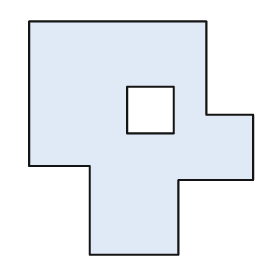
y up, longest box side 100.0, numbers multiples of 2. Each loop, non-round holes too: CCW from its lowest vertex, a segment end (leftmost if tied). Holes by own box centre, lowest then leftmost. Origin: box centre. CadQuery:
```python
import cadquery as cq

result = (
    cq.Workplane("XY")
    .moveTo(-22.0, -50.0)
    .lineTo(16.0, -50.0)
    .lineTo(16.0, -18.0)
    .lineTo(48.0, -18.0)
    .lineTo(48.0, 10.0)
    .lineTo(28.0, 10.0)
    .lineTo(28.0, 50.0)
    .lineTo(-48.0, 50.0)
    .lineTo(-48.0, -12.0)
    .lineTo(-22.0, -12.0)
    .close()
    .moveTo(-6.0, 2.0)
    .lineTo(14.0, 2.0)
    .lineTo(14.0, 22.0)
    .lineTo(-6.0, 22.0)
    .close()
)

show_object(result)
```